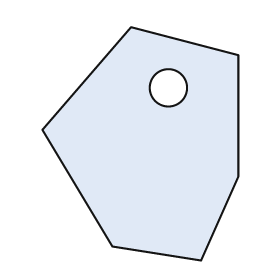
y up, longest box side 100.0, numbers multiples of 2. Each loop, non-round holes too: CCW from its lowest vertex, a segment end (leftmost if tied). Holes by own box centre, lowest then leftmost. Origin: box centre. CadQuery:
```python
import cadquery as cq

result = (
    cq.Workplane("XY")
    .moveTo(26.0, -50.0)
    .lineTo(42.0, -14.0)
    .lineTo(42.0, 38.0)
    .lineTo(-4.0, 50.0)
    .lineTo(-42.0, 6.0)
    .lineTo(-12.0, -44.0)
    .close()
    .moveTo(12.0, 24.0)
    .circle(8.0)
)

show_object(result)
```